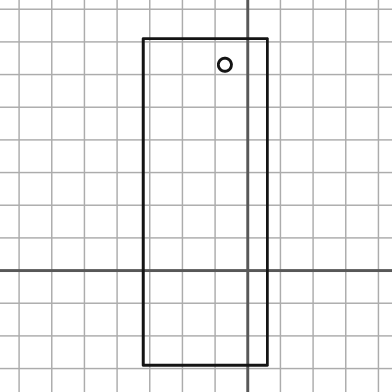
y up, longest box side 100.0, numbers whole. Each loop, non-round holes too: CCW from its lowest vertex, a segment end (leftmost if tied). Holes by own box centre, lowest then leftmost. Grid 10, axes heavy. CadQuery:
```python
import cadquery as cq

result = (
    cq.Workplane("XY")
    .moveTo(-32.0, -29.0)
    .lineTo(6.0, -29.0)
    .lineTo(6.0, 71.0)
    .lineTo(-32.0, 71.0)
    .close()
    .moveTo(-7.0, 63.0)
    .circle(2.0)
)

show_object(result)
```